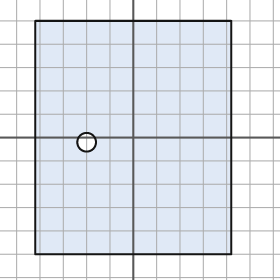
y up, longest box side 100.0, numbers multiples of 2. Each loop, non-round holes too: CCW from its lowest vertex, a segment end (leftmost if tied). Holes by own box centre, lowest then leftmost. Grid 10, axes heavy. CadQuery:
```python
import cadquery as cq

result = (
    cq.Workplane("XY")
    .moveTo(-42.0, -50.0)
    .lineTo(42.0, -50.0)
    .lineTo(42.0, 50.0)
    .lineTo(-42.0, 50.0)
    .close()
    .moveTo(-20.0, -2.0)
    .circle(4.0)
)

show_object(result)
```